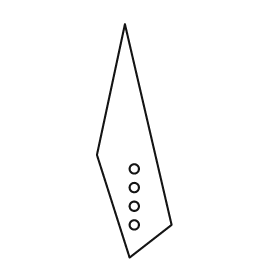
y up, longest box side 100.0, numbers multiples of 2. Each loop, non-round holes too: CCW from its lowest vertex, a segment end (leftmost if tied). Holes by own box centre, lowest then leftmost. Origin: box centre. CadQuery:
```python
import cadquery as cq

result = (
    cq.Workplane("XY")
    .moveTo(-2.0, -50.0)
    .lineTo(16.0, -36.0)
    .lineTo(-4.0, 50.0)
    .lineTo(-16.0, -6.0)
    .close()
    .moveTo(0.0, -36.0)
    .circle(2.0)
    .moveTo(0.0, -28.0)
    .circle(2.0)
    .moveTo(0.0, -20.0)
    .circle(2.0)
    .moveTo(0.0, -12.0)
    .circle(2.0)
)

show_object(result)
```